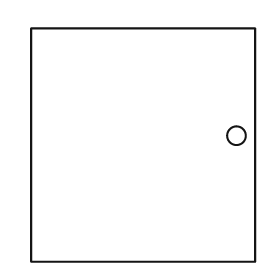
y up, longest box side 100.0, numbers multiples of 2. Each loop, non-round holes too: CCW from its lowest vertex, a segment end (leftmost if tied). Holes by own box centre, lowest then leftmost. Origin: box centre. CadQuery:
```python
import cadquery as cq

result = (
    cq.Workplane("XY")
    .moveTo(-48.0, -50.0)
    .lineTo(48.0, -50.0)
    .lineTo(48.0, 50.0)
    .lineTo(-48.0, 50.0)
    .close()
    .moveTo(40.0, 4.0)
    .circle(4.0)
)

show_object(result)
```